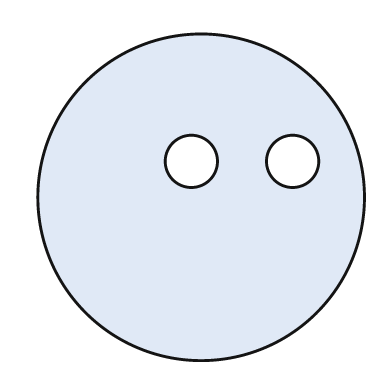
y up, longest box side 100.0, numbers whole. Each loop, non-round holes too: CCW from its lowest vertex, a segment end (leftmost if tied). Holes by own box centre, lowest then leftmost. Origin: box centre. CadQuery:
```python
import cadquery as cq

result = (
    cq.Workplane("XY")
    .moveTo(0.0, 0.0)
    .circle(50.0)
    .moveTo(-3.0, 11.0)
    .circle(8.0)
    .moveTo(28.0, 11.0)
    .circle(8.0)
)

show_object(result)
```